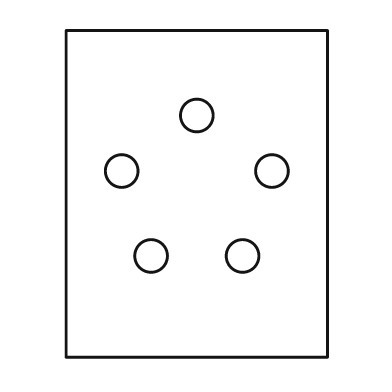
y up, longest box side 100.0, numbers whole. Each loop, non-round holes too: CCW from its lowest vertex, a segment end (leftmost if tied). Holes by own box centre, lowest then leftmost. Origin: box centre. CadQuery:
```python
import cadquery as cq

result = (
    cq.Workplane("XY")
    .moveTo(-40.0, -50.0)
    .lineTo(40.0, -50.0)
    .lineTo(40.0, 50.0)
    .lineTo(-40.0, 50.0)
    .close()
    .moveTo(-14.0, -19.0)
    .circle(5.0)
    .moveTo(14.0, -19.0)
    .circle(5.0)
    .moveTo(-23.0, 7.0)
    .circle(5.0)
    .moveTo(23.0, 7.0)
    .circle(5.0)
    .moveTo(0.0, 24.0)
    .circle(5.0)
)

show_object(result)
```